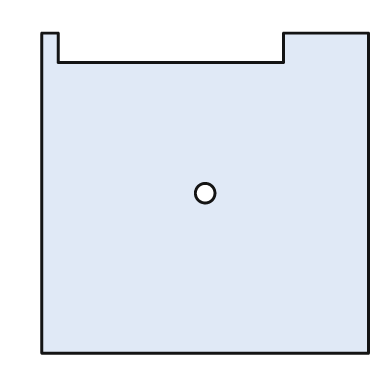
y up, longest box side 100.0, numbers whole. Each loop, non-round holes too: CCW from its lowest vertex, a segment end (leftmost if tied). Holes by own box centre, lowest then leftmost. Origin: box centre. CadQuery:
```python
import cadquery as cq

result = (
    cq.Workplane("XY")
    .moveTo(-50.0, -49.0)
    .lineTo(50.0, -49.0)
    .lineTo(50.0, 49.0)
    .lineTo(24.0, 49.0)
    .lineTo(24.0, 40.0)
    .lineTo(-45.0, 40.0)
    .lineTo(-45.0, 49.0)
    .lineTo(-50.0, 49.0)
    .close()
    .moveTo(0.0, 0.0)
    .circle(3.0)
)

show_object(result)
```